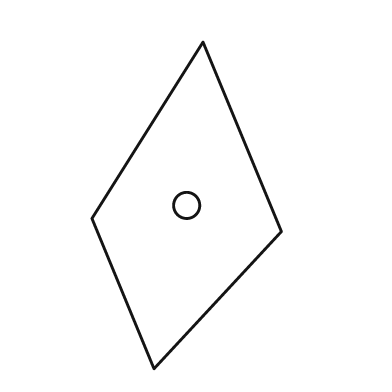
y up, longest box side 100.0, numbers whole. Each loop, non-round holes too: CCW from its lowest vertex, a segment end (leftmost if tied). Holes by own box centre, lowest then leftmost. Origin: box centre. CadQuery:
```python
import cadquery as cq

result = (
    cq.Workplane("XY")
    .moveTo(-10.0, -50.0)
    .lineTo(29.0, -8.0)
    .lineTo(5.0, 50.0)
    .lineTo(-29.0, -4.0)
    .close()
    .moveTo(0.0, 0.0)
    .circle(4.0)
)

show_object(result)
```